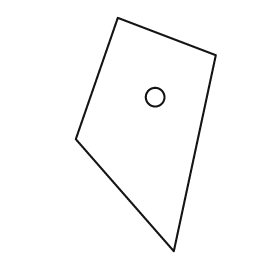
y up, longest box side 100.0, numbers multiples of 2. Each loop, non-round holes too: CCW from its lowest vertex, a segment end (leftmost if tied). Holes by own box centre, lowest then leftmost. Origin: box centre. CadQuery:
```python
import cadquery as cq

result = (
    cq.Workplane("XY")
    .moveTo(12.0, -50.0)
    .lineTo(30.0, 34.0)
    .lineTo(-12.0, 50.0)
    .lineTo(-30.0, -2.0)
    .close()
    .moveTo(4.0, 16.0)
    .circle(4.0)
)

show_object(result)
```